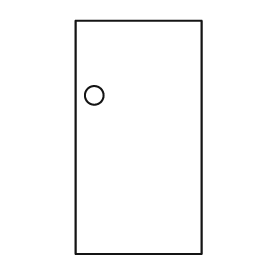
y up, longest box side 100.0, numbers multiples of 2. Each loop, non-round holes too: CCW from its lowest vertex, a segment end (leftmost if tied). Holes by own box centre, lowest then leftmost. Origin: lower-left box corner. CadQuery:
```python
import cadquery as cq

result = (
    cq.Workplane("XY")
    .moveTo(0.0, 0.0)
    .lineTo(54.0, 0.0)
    .lineTo(54.0, 100.0)
    .lineTo(0.0, 100.0)
    .close()
    .moveTo(8.0, 68.0)
    .circle(4.0)
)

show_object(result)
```